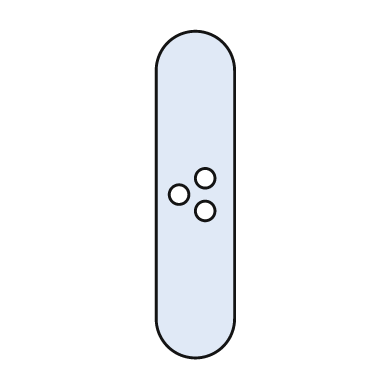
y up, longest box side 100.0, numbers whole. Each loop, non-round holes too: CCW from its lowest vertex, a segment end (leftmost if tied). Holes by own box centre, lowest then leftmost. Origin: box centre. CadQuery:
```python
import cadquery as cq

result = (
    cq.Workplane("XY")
    .moveTo(-12.0, -38.0)
    .threePointArc((0.0, -50.0), (12.0, -38.0))
    .lineTo(12.0, 38.0)
    .threePointArc((0.0, 50.0), (-12.0, 38.0))
    .close()
    .moveTo(3.0, -5.0)
    .circle(3.0)
    .moveTo(-5.0, 0.0)
    .circle(3.0)
    .moveTo(3.0, 5.0)
    .circle(3.0)
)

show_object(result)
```